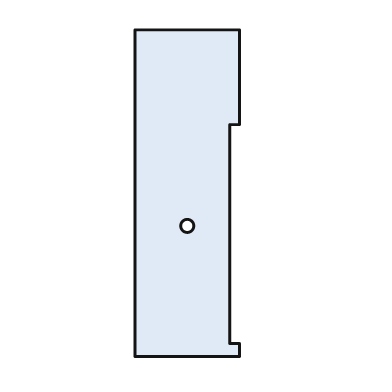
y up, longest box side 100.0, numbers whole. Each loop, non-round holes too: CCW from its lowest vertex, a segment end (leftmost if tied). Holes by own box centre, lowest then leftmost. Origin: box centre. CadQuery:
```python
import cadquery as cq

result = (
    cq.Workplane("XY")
    .moveTo(-16.0, -50.0)
    .lineTo(16.0, -50.0)
    .lineTo(16.0, -46.0)
    .lineTo(13.0, -46.0)
    .lineTo(13.0, 21.0)
    .lineTo(16.0, 21.0)
    .lineTo(16.0, 50.0)
    .lineTo(-16.0, 50.0)
    .close()
    .moveTo(0.0, -10.0)
    .circle(2.0)
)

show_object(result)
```